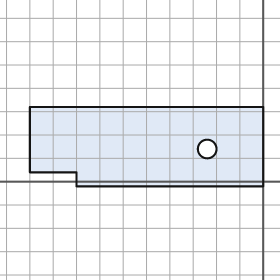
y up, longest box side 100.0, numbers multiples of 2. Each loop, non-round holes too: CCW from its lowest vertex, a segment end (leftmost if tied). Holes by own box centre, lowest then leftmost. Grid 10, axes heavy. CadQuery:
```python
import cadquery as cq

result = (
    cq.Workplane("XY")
    .moveTo(-80.0, -2.0)
    .lineTo(0.0, -2.0)
    .lineTo(0.0, 32.0)
    .lineTo(-100.0, 32.0)
    .lineTo(-100.0, 4.0)
    .lineTo(-80.0, 4.0)
    .close()
    .moveTo(-24.0, 14.0)
    .circle(4.0)
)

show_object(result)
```